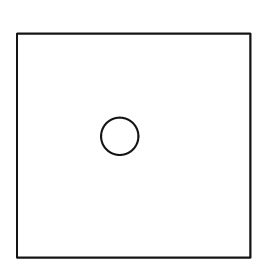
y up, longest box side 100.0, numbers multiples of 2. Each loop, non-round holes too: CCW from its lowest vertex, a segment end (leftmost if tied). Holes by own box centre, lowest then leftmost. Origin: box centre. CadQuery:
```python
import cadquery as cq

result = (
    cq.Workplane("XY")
    .moveTo(-50.0, -48.0)
    .lineTo(50.0, -48.0)
    .lineTo(50.0, 48.0)
    .lineTo(-50.0, 48.0)
    .close()
    .moveTo(-6.0, 4.0)
    .circle(8.0)
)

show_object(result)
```